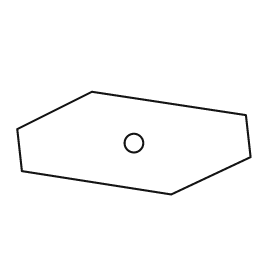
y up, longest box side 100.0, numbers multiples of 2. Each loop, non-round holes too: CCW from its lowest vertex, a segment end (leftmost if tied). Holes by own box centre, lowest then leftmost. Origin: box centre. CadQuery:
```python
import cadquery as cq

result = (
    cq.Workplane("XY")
    .moveTo(16.0, -22.0)
    .lineTo(50.0, -6.0)
    .lineTo(48.0, 12.0)
    .lineTo(-18.0, 22.0)
    .lineTo(-50.0, 6.0)
    .lineTo(-48.0, -12.0)
    .close()
    .moveTo(0.0, 0.0)
    .circle(4.0)
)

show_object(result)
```